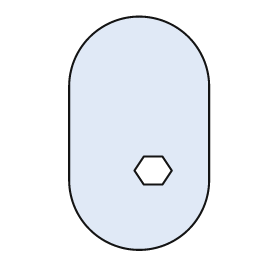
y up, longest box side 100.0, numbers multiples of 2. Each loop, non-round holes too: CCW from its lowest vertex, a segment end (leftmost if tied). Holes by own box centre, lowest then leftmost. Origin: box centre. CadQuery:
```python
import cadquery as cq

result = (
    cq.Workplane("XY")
    .moveTo(-30.0, -20.0)
    .threePointArc((0.0, -50.0), (30.0, -20.0))
    .lineTo(30.0, 20.0)
    .threePointArc((0.0, 50.0), (-30.0, 20.0))
    .close()
    .moveTo(2.0, -22.0)
    .lineTo(10.0, -22.0)
    .lineTo(14.0, -16.0)
    .lineTo(10.0, -10.0)
    .lineTo(2.0, -10.0)
    .lineTo(-2.0, -16.0)
    .close()
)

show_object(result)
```